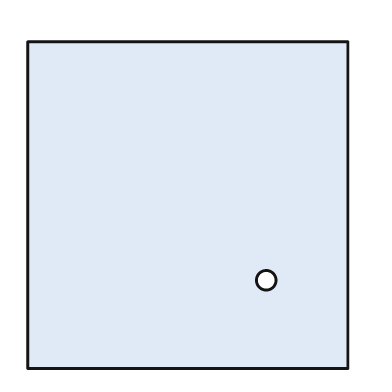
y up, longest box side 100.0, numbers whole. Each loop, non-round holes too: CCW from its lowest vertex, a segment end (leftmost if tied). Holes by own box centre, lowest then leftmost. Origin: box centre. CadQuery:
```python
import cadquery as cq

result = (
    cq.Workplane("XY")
    .moveTo(-49.0, -50.0)
    .lineTo(49.0, -50.0)
    .lineTo(49.0, 50.0)
    .lineTo(-49.0, 50.0)
    .close()
    .moveTo(24.0, -23.0)
    .circle(3.0)
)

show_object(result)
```